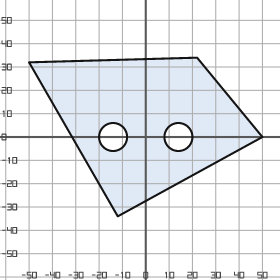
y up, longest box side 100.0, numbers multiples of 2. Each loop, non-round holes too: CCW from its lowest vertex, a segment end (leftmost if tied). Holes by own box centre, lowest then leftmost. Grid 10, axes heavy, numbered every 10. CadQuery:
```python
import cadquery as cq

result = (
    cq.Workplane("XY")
    .moveTo(-12.0, -34.0)
    .lineTo(50.0, 0.0)
    .lineTo(22.0, 34.0)
    .lineTo(-50.0, 32.0)
    .close()
    .moveTo(-14.0, 0.0)
    .circle(6.0)
    .moveTo(14.0, 0.0)
    .circle(6.0)
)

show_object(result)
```